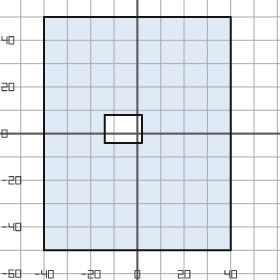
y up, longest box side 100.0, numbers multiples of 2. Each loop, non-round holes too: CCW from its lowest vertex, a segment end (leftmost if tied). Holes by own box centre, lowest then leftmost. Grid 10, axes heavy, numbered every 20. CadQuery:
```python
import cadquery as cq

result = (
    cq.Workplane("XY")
    .moveTo(-40.0, -50.0)
    .lineTo(40.0, -50.0)
    .lineTo(40.0, 50.0)
    .lineTo(-40.0, 50.0)
    .close()
    .moveTo(-14.0, -4.0)
    .lineTo(2.0, -4.0)
    .lineTo(2.0, 8.0)
    .lineTo(-14.0, 8.0)
    .close()
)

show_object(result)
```